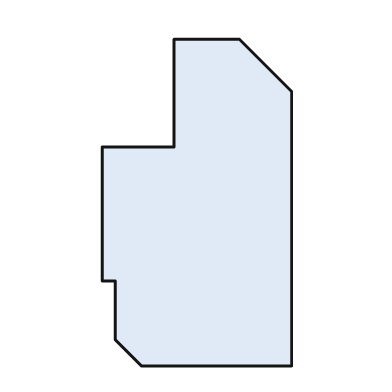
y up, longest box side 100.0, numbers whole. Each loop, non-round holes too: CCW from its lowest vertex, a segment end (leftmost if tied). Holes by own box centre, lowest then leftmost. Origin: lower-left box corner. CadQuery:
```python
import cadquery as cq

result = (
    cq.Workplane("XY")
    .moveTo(12.0, 0.0)
    .lineTo(58.0, 0.0)
    .lineTo(58.0, 84.0)
    .lineTo(42.0, 100.0)
    .lineTo(22.0, 100.0)
    .lineTo(22.0, 67.0)
    .lineTo(0.0, 67.0)
    .lineTo(0.0, 26.0)
    .lineTo(4.0, 26.0)
    .lineTo(4.0, 8.0)
    .close()
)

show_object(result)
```